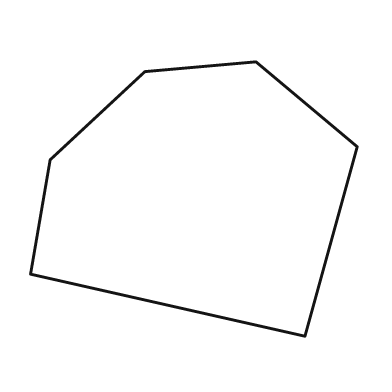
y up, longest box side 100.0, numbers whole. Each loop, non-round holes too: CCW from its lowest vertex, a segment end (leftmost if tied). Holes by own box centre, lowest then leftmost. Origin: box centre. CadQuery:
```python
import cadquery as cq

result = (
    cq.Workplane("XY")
    .moveTo(34.0, -42.0)
    .lineTo(50.0, 16.0)
    .lineTo(19.0, 42.0)
    .lineTo(-15.0, 39.0)
    .lineTo(-44.0, 12.0)
    .lineTo(-50.0, -23.0)
    .close()
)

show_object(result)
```